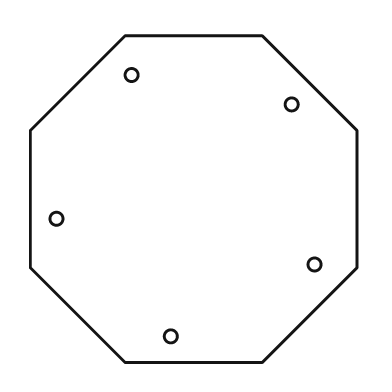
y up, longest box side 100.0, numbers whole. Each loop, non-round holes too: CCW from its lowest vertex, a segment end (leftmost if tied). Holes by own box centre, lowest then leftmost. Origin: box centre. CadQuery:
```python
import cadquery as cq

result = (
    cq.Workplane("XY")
    .moveTo(-21.0, -50.0)
    .lineTo(21.0, -50.0)
    .lineTo(50.0, -21.0)
    .lineTo(50.0, 21.0)
    .lineTo(21.0, 50.0)
    .lineTo(-21.0, 50.0)
    .lineTo(-50.0, 21.0)
    .lineTo(-50.0, -21.0)
    .close()
    .moveTo(-7.0, -42.0)
    .circle(2.0)
    .moveTo(37.0, -20.0)
    .circle(2.0)
    .moveTo(-42.0, -6.0)
    .circle(2.0)
    .moveTo(30.0, 29.0)
    .circle(2.0)
    .moveTo(-19.0, 38.0)
    .circle(2.0)
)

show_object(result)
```